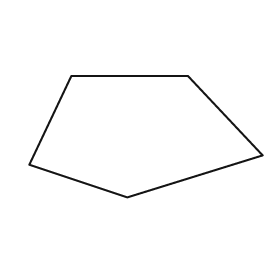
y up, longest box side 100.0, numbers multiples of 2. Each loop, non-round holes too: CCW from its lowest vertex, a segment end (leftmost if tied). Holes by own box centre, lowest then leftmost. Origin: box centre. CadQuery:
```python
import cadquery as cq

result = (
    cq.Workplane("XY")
    .moveTo(-8.0, -26.0)
    .lineTo(50.0, -8.0)
    .lineTo(18.0, 26.0)
    .lineTo(-32.0, 26.0)
    .lineTo(-50.0, -12.0)
    .close()
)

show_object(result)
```